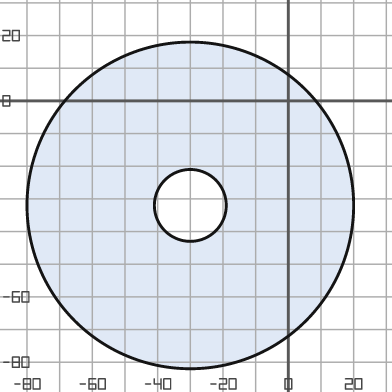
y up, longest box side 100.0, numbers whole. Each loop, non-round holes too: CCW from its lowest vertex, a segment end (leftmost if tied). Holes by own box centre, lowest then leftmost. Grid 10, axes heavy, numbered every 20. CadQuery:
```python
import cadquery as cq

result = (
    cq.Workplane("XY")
    .moveTo(-30.0, -32.0)
    .circle(50.0)
    .moveTo(-30.0, -32.0)
    .circle(11.0)
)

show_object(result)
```